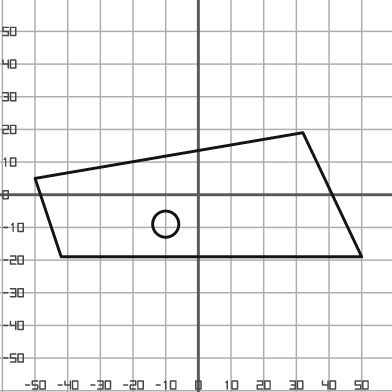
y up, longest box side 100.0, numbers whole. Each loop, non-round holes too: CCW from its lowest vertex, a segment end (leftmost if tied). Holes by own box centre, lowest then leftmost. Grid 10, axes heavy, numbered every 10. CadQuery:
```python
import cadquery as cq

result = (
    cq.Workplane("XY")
    .moveTo(-42.0, -19.0)
    .lineTo(50.0, -19.0)
    .lineTo(32.0, 19.0)
    .lineTo(-50.0, 5.0)
    .close()
    .moveTo(-10.0, -9.0)
    .circle(4.0)
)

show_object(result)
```